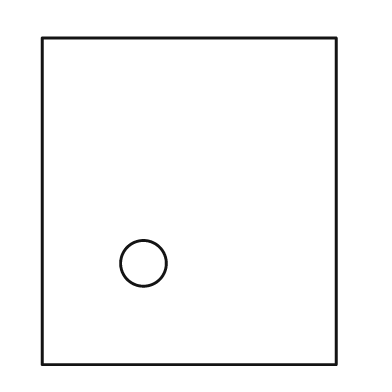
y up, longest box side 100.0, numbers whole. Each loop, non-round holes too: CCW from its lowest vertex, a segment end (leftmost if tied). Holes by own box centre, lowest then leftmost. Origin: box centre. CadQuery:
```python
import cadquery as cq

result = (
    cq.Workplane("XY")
    .moveTo(-45.0, -50.0)
    .lineTo(45.0, -50.0)
    .lineTo(45.0, 50.0)
    .lineTo(-45.0, 50.0)
    .close()
    .moveTo(-14.0, -19.0)
    .circle(7.0)
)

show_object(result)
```